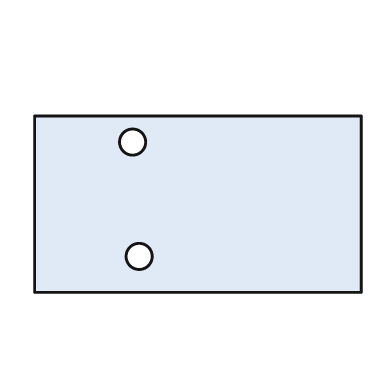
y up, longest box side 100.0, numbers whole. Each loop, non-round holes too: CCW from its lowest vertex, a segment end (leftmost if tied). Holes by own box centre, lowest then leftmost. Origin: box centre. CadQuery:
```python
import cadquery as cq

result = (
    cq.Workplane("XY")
    .moveTo(-50.0, -27.0)
    .lineTo(50.0, -27.0)
    .lineTo(50.0, 27.0)
    .lineTo(-50.0, 27.0)
    .close()
    .moveTo(-18.0, -16.0)
    .circle(4.0)
    .moveTo(-20.0, 19.0)
    .circle(4.0)
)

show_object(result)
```